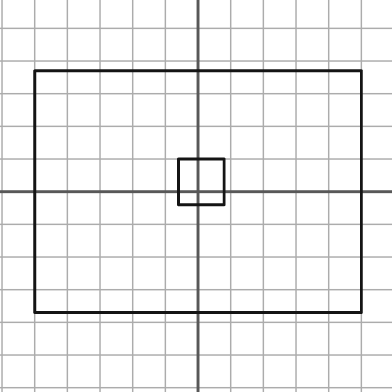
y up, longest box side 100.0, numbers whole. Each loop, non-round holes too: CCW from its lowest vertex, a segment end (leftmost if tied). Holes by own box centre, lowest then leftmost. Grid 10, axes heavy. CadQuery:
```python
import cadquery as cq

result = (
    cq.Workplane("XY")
    .moveTo(-50.0, -37.0)
    .lineTo(50.0, -37.0)
    .lineTo(50.0, 37.0)
    .lineTo(-50.0, 37.0)
    .close()
    .moveTo(-6.0, -4.0)
    .lineTo(8.0, -4.0)
    .lineTo(8.0, 10.0)
    .lineTo(-6.0, 10.0)
    .close()
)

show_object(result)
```